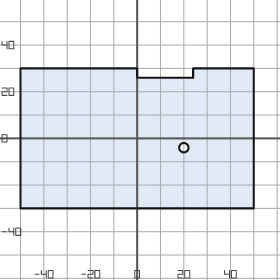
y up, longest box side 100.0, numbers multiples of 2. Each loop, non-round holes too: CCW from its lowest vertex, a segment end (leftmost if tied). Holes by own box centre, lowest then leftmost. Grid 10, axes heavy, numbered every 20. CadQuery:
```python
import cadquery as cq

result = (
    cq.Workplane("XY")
    .moveTo(-50.0, -30.0)
    .lineTo(50.0, -30.0)
    .lineTo(50.0, 30.0)
    .lineTo(24.0, 30.0)
    .lineTo(24.0, 26.0)
    .lineTo(0.0, 26.0)
    .lineTo(0.0, 30.0)
    .lineTo(-50.0, 30.0)
    .close()
    .moveTo(20.0, -4.0)
    .circle(2.0)
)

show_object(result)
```